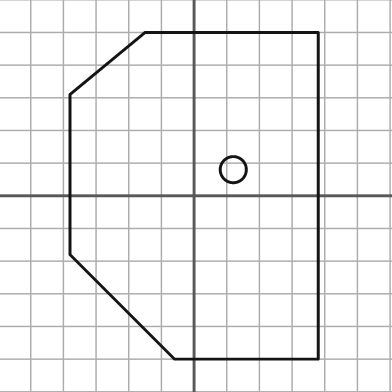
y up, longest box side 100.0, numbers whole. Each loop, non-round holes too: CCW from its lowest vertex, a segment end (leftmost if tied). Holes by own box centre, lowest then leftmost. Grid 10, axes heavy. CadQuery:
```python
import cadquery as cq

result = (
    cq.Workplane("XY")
    .moveTo(-6.0, -50.0)
    .lineTo(38.0, -50.0)
    .lineTo(38.0, 50.0)
    .lineTo(-15.0, 50.0)
    .lineTo(-38.0, 31.0)
    .lineTo(-38.0, -18.0)
    .close()
    .moveTo(12.0, 8.0)
    .circle(4.0)
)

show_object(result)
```